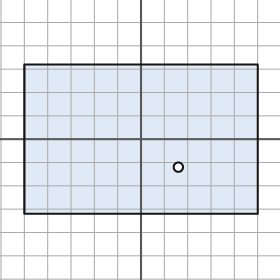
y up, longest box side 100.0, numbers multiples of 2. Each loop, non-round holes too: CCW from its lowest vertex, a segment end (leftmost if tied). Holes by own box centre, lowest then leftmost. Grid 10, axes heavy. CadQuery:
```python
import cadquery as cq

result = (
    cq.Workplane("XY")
    .moveTo(-50.0, -32.0)
    .lineTo(50.0, -32.0)
    .lineTo(50.0, 32.0)
    .lineTo(-50.0, 32.0)
    .close()
    .moveTo(16.0, -12.0)
    .circle(2.0)
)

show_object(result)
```